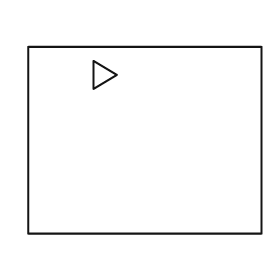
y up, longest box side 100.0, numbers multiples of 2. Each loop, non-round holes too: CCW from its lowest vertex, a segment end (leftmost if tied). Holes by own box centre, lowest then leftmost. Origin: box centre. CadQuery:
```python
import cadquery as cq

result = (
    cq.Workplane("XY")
    .moveTo(-50.0, -40.0)
    .lineTo(50.0, -40.0)
    .lineTo(50.0, 40.0)
    .lineTo(-50.0, 40.0)
    .close()
    .moveTo(-22.0, 22.0)
    .lineTo(-12.0, 28.0)
    .lineTo(-22.0, 34.0)
    .close()
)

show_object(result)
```